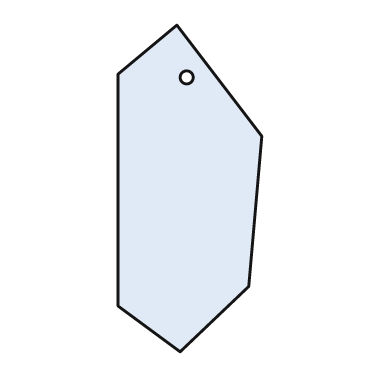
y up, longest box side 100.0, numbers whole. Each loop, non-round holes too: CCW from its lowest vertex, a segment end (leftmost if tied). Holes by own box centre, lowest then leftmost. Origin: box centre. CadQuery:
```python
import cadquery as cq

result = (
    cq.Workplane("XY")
    .moveTo(-3.0, -50.0)
    .lineTo(18.0, -30.0)
    .lineTo(22.0, 16.0)
    .lineTo(-4.0, 50.0)
    .lineTo(-22.0, 35.0)
    .lineTo(-22.0, -36.0)
    .close()
    .moveTo(-1.0, 34.0)
    .circle(2.0)
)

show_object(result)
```